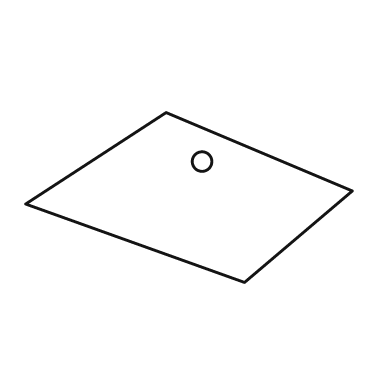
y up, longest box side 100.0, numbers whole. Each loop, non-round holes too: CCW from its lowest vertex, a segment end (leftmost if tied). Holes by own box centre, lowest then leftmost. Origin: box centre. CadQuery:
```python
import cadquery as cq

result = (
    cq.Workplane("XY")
    .moveTo(17.0, -26.0)
    .lineTo(50.0, 2.0)
    .lineTo(-7.0, 26.0)
    .lineTo(-50.0, -2.0)
    .close()
    .moveTo(4.0, 11.0)
    .circle(3.0)
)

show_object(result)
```